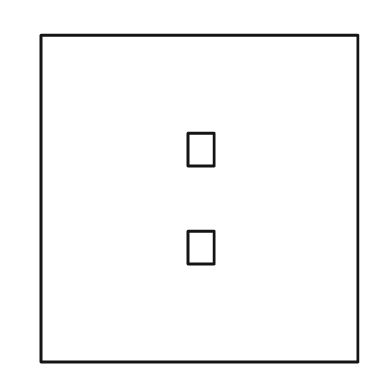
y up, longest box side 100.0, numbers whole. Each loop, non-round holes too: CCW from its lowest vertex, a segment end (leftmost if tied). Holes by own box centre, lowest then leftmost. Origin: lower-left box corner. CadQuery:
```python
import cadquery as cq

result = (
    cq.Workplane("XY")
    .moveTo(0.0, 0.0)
    .lineTo(97.0, 0.0)
    .lineTo(97.0, 100.0)
    .lineTo(0.0, 100.0)
    .close()
    .moveTo(45.0, 30.0)
    .lineTo(53.0, 30.0)
    .lineTo(53.0, 40.0)
    .lineTo(45.0, 40.0)
    .close()
    .moveTo(45.0, 60.0)
    .lineTo(53.0, 60.0)
    .lineTo(53.0, 70.0)
    .lineTo(45.0, 70.0)
    .close()
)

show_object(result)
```